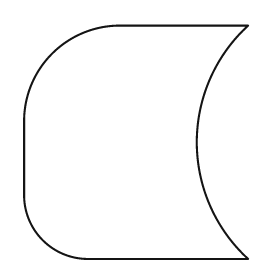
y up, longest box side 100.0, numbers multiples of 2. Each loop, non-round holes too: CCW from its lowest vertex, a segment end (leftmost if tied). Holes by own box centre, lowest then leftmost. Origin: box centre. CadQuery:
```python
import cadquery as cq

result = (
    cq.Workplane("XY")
    .moveTo(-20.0, -50.0)
    .lineTo(48.0, -50.0)
    .threePointArc((26.0, 0.0), (48.0, 50.0))
    .lineTo(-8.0, 50.0)
    .threePointArc((-36.0, 38.0), (-48.0, 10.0))
    .lineTo(-48.0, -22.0)
    .threePointArc((-40.0, -42.0), (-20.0, -50.0))
    .close()
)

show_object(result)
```